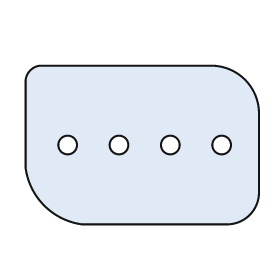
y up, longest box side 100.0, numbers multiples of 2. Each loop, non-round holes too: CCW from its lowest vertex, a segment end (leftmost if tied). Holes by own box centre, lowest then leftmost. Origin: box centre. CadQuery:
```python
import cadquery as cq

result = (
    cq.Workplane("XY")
    .moveTo(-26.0, -34.0)
    .lineTo(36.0, -34.0)
    .threePointArc((46.0, -30.0), (50.0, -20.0))
    .lineTo(50.0, 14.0)
    .threePointArc((44.0, 28.0), (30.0, 34.0))
    .lineTo(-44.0, 34.0)
    .threePointArc((-48.0, 32.0), (-50.0, 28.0))
    .lineTo(-50.0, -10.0)
    .threePointArc((-42.0, -26.0), (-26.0, -34.0))
    .close()
    .moveTo(-32.0, 0.0)
    .circle(4.0)
    .moveTo(-10.0, 0.0)
    .circle(4.0)
    .moveTo(12.0, 0.0)
    .circle(4.0)
    .moveTo(34.0, 0.0)
    .circle(4.0)
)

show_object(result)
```